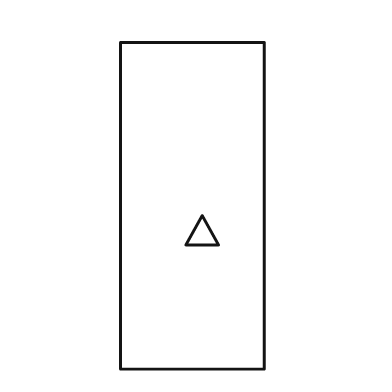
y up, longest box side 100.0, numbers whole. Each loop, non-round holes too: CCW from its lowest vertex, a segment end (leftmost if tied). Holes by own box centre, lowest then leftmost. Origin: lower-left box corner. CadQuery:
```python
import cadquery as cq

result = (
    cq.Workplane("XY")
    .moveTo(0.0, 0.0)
    .lineTo(44.0, 0.0)
    .lineTo(44.0, 100.0)
    .lineTo(0.0, 100.0)
    .close()
    .moveTo(20.0, 38.0)
    .lineTo(30.0, 38.0)
    .lineTo(25.0, 47.0)
    .close()
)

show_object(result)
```